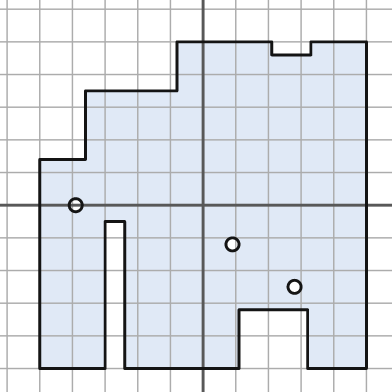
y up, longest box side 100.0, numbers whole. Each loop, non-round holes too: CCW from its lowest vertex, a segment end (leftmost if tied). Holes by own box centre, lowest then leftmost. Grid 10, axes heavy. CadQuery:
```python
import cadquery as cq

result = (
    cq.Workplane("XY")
    .moveTo(-50.0, -50.0)
    .lineTo(-30.0, -50.0)
    .lineTo(-30.0, -5.0)
    .lineTo(-24.0, -5.0)
    .lineTo(-24.0, -50.0)
    .lineTo(11.0, -50.0)
    .lineTo(11.0, -32.0)
    .lineTo(32.0, -32.0)
    .lineTo(32.0, -50.0)
    .lineTo(50.0, -50.0)
    .lineTo(50.0, 50.0)
    .lineTo(33.0, 50.0)
    .lineTo(33.0, 46.0)
    .lineTo(21.0, 46.0)
    .lineTo(21.0, 50.0)
    .lineTo(-8.0, 50.0)
    .lineTo(-8.0, 35.0)
    .lineTo(-36.0, 35.0)
    .lineTo(-36.0, 14.0)
    .lineTo(-50.0, 14.0)
    .close()
    .moveTo(28.0, -25.0)
    .circle(2.0)
    .moveTo(9.0, -12.0)
    .circle(2.0)
    .moveTo(-39.0, 0.0)
    .circle(2.0)
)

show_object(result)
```